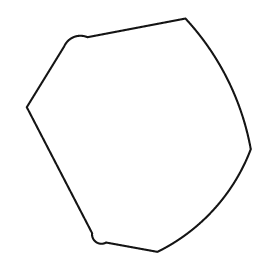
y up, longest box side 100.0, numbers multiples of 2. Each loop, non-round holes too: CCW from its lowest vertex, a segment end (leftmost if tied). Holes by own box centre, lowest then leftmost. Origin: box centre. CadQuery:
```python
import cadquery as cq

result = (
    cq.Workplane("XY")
    .moveTo(8.0, -50.0)
    .threePointArc((32.0, -32.0), (48.0, -6.0))
    .threePointArc((38.0, 24.0), (20.0, 50.0))
    .lineTo(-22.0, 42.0)
    .threePointArc((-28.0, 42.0), (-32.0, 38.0))
    .lineTo(-48.0, 12.0)
    .lineTo(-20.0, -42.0)
    .threePointArc((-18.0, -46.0), (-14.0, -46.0))
    .close()
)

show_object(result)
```